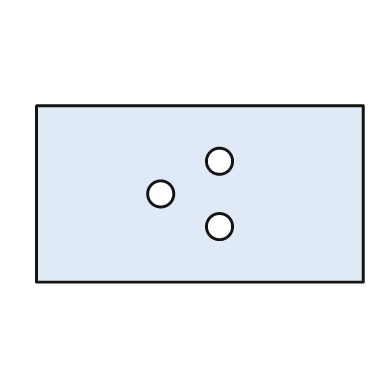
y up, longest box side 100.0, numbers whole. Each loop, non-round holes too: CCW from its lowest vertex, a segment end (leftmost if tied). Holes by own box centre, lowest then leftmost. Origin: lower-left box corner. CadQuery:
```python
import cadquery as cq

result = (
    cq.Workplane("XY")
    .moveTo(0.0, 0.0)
    .lineTo(100.0, 0.0)
    .lineTo(100.0, 54.0)
    .lineTo(0.0, 54.0)
    .close()
    .moveTo(56.0, 17.0)
    .circle(4.0)
    .moveTo(38.0, 27.0)
    .circle(4.0)
    .moveTo(56.0, 37.0)
    .circle(4.0)
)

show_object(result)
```